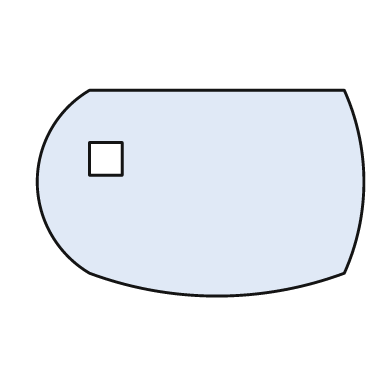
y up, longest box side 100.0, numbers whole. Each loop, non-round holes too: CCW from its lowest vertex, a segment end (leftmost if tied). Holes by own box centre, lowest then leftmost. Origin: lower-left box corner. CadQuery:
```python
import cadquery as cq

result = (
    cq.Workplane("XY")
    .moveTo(16.0, 7.0)
    .threePointArc((55.0, 0.0), (94.0, 7.0))
    .threePointArc((100.0, 35.0), (94.0, 63.0))
    .lineTo(16.0, 63.0)
    .threePointArc((0.0, 35.0), (16.0, 7.0))
    .close()
    .moveTo(16.0, 37.0)
    .lineTo(26.0, 37.0)
    .lineTo(26.0, 47.0)
    .lineTo(16.0, 47.0)
    .close()
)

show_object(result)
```